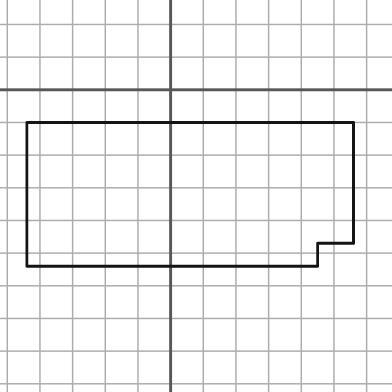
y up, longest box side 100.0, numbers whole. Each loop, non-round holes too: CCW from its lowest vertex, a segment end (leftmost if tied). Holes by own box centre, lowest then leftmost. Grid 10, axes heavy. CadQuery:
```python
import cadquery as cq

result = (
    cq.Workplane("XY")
    .moveTo(-44.0, -54.0)
    .lineTo(45.0, -54.0)
    .lineTo(45.0, -47.0)
    .lineTo(56.0, -47.0)
    .lineTo(56.0, -10.0)
    .lineTo(-44.0, -10.0)
    .close()
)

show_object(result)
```